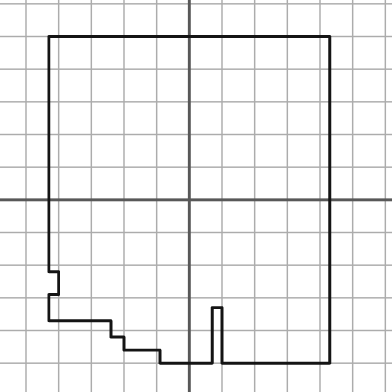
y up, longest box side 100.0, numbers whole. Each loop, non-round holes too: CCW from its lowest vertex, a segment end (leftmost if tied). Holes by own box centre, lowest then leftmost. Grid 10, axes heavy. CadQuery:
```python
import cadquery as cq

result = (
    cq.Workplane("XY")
    .moveTo(-9.0, -50.0)
    .lineTo(7.0, -50.0)
    .lineTo(7.0, -33.0)
    .lineTo(10.0, -33.0)
    .lineTo(10.0, -50.0)
    .lineTo(43.0, -50.0)
    .lineTo(43.0, 50.0)
    .lineTo(-43.0, 50.0)
    .lineTo(-43.0, -22.0)
    .lineTo(-40.0, -22.0)
    .lineTo(-40.0, -29.0)
    .lineTo(-43.0, -29.0)
    .lineTo(-43.0, -37.0)
    .lineTo(-24.0, -37.0)
    .lineTo(-24.0, -42.0)
    .lineTo(-20.0, -42.0)
    .lineTo(-20.0, -46.0)
    .lineTo(-9.0, -46.0)
    .close()
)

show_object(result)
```